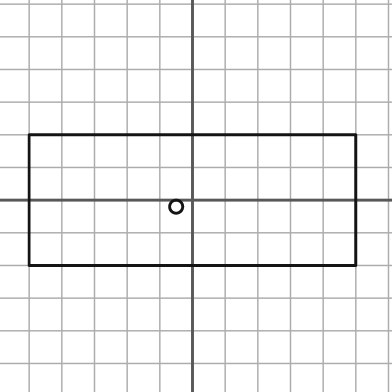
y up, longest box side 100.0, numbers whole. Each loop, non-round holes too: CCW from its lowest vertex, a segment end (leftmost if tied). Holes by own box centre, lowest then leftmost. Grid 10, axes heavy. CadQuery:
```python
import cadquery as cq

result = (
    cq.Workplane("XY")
    .moveTo(-50.0, -20.0)
    .lineTo(50.0, -20.0)
    .lineTo(50.0, 20.0)
    .lineTo(-50.0, 20.0)
    .close()
    .moveTo(-5.0, -2.0)
    .circle(2.0)
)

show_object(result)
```